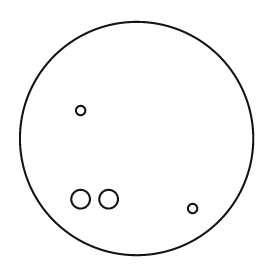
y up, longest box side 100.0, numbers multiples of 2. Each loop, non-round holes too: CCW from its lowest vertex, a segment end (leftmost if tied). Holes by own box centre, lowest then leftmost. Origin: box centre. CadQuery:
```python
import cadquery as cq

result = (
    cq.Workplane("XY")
    .moveTo(0.0, 0.0)
    .circle(50.0)
    .moveTo(24.0, -30.0)
    .circle(2.0)
    .moveTo(-24.0, -26.0)
    .circle(4.0)
    .moveTo(-12.0, -26.0)
    .circle(4.0)
    .moveTo(-24.0, 12.0)
    .circle(2.0)
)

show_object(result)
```